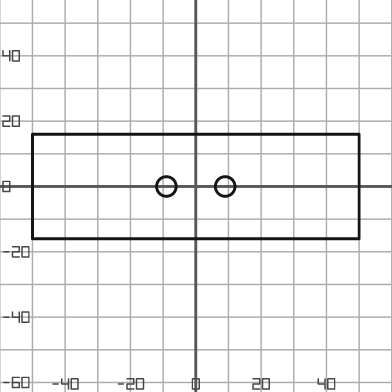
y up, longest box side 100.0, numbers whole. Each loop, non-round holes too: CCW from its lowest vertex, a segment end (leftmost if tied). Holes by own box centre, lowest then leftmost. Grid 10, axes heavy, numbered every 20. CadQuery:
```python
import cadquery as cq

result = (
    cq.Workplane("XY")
    .moveTo(-50.0, -16.0)
    .lineTo(50.0, -16.0)
    .lineTo(50.0, 16.0)
    .lineTo(-50.0, 16.0)
    .close()
    .moveTo(-9.0, 0.0)
    .circle(3.0)
    .moveTo(9.0, 0.0)
    .circle(3.0)
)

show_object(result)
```